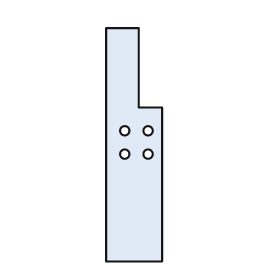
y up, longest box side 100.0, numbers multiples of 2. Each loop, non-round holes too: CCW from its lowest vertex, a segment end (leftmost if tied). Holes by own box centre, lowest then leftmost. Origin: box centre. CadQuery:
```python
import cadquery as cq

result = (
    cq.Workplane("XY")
    .moveTo(-12.0, -50.0)
    .lineTo(12.0, -50.0)
    .lineTo(12.0, 16.0)
    .lineTo(2.0, 16.0)
    .lineTo(2.0, 50.0)
    .lineTo(-12.0, 50.0)
    .close()
    .moveTo(-4.0, -4.0)
    .circle(2.0)
    .moveTo(6.0, -4.0)
    .circle(2.0)
    .moveTo(-4.0, 6.0)
    .circle(2.0)
    .moveTo(6.0, 6.0)
    .circle(2.0)
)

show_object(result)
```